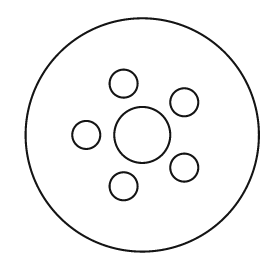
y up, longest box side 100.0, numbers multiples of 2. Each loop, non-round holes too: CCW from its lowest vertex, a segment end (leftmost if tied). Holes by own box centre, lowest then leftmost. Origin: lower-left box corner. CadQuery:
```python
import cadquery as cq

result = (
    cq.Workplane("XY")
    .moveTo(50.0, 50.0)
    .circle(50.0)
    .moveTo(42.0, 28.0)
    .circle(6.0)
    .moveTo(68.0, 36.0)
    .circle(6.0)
    .moveTo(26.0, 50.0)
    .circle(6.0)
    .moveTo(50.0, 50.0)
    .circle(12.0)
    .moveTo(68.0, 64.0)
    .circle(6.0)
    .moveTo(42.0, 72.0)
    .circle(6.0)
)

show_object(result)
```